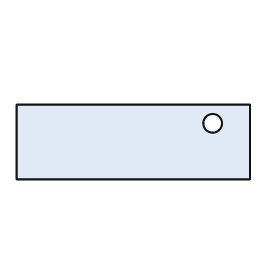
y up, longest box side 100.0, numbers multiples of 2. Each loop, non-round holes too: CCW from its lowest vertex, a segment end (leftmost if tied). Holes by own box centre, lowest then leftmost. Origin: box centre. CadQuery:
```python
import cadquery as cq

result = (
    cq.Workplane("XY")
    .moveTo(-50.0, -16.0)
    .lineTo(50.0, -16.0)
    .lineTo(50.0, 16.0)
    .lineTo(-50.0, 16.0)
    .close()
    .moveTo(34.0, 8.0)
    .circle(4.0)
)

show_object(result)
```